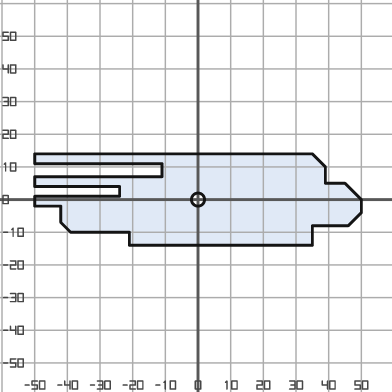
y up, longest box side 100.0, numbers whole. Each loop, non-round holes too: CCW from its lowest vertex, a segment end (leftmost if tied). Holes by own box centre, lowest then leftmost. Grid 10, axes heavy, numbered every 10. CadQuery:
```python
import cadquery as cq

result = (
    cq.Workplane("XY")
    .moveTo(-21.0, -14.0)
    .lineTo(35.0, -14.0)
    .lineTo(35.0, -8.0)
    .lineTo(46.0, -8.0)
    .lineTo(50.0, -4.0)
    .lineTo(50.0, 0.0)
    .lineTo(45.0, 5.0)
    .lineTo(39.0, 5.0)
    .lineTo(39.0, 10.0)
    .lineTo(35.0, 14.0)
    .lineTo(-50.0, 14.0)
    .lineTo(-50.0, 11.0)
    .lineTo(-11.0, 11.0)
    .lineTo(-11.0, 7.0)
    .lineTo(-50.0, 7.0)
    .lineTo(-50.0, 4.0)
    .lineTo(-24.0, 4.0)
    .lineTo(-24.0, 1.0)
    .lineTo(-50.0, 1.0)
    .lineTo(-50.0, -2.0)
    .lineTo(-42.0, -2.0)
    .lineTo(-42.0, -7.0)
    .lineTo(-39.0, -10.0)
    .lineTo(-21.0, -10.0)
    .close()
    .moveTo(0.0, 0.0)
    .circle(2.0)
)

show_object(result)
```